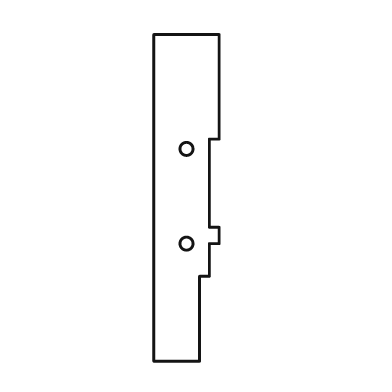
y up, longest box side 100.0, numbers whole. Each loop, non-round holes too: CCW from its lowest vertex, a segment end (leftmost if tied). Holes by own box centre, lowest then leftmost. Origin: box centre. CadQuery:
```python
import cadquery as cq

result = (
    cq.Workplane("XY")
    .moveTo(-10.0, -50.0)
    .lineTo(4.0, -50.0)
    .lineTo(4.0, -24.0)
    .lineTo(7.0, -24.0)
    .lineTo(7.0, -14.0)
    .lineTo(10.0, -14.0)
    .lineTo(10.0, -9.0)
    .lineTo(7.0, -9.0)
    .lineTo(7.0, 18.0)
    .lineTo(10.0, 18.0)
    .lineTo(10.0, 50.0)
    .lineTo(-10.0, 50.0)
    .close()
    .moveTo(0.0, -14.0)
    .circle(2.0)
    .moveTo(0.0, 15.0)
    .circle(2.0)
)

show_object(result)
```